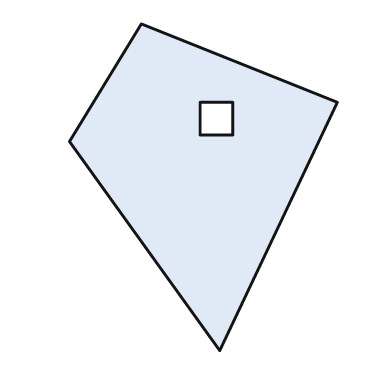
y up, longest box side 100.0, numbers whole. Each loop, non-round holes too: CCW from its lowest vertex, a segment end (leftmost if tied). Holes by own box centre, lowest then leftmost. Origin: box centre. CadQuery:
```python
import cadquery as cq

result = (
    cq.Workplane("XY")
    .moveTo(5.0, -50.0)
    .lineTo(41.0, 26.0)
    .lineTo(-19.0, 50.0)
    .lineTo(-41.0, 14.0)
    .close()
    .moveTo(-1.0, 16.0)
    .lineTo(9.0, 16.0)
    .lineTo(9.0, 26.0)
    .lineTo(-1.0, 26.0)
    .close()
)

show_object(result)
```